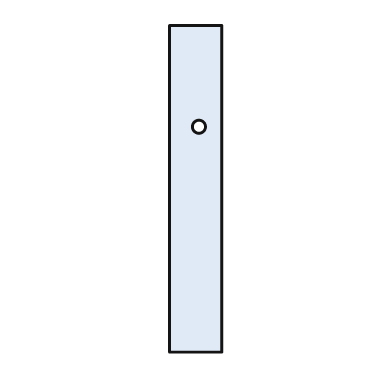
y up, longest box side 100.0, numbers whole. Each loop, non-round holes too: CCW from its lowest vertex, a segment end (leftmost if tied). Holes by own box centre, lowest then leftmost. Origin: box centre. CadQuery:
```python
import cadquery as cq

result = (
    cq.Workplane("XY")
    .moveTo(-8.0, -50.0)
    .lineTo(8.0, -50.0)
    .lineTo(8.0, 50.0)
    .lineTo(-8.0, 50.0)
    .close()
    .moveTo(1.0, 19.0)
    .circle(2.0)
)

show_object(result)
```